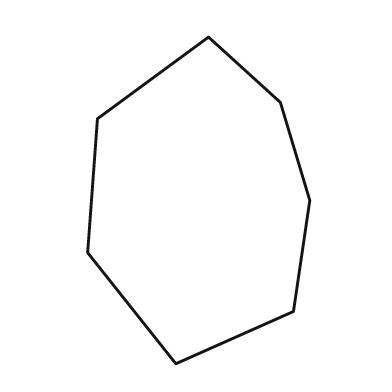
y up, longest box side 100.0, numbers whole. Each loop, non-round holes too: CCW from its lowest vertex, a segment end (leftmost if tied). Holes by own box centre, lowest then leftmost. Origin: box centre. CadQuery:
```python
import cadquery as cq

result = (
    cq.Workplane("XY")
    .moveTo(-7.0, -50.0)
    .lineTo(29.0, -34.0)
    .lineTo(34.0, 0.0)
    .lineTo(25.0, 30.0)
    .lineTo(3.0, 50.0)
    .lineTo(-31.0, 25.0)
    .lineTo(-34.0, -16.0)
    .close()
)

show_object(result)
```